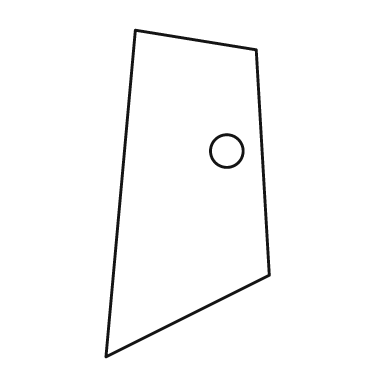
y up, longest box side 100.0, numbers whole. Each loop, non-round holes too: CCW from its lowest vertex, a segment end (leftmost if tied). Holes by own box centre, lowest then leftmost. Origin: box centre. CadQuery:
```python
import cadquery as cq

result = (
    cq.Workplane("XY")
    .moveTo(-25.0, -50.0)
    .lineTo(25.0, -25.0)
    .lineTo(21.0, 44.0)
    .lineTo(-16.0, 50.0)
    .close()
    .moveTo(12.0, 13.0)
    .circle(5.0)
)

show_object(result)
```